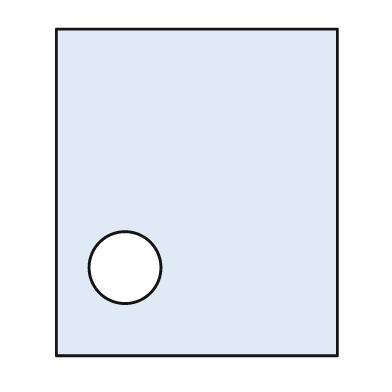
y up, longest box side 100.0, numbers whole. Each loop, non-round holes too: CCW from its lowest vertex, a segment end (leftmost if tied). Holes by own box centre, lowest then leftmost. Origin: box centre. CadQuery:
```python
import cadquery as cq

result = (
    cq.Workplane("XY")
    .moveTo(-43.0, -50.0)
    .lineTo(43.0, -50.0)
    .lineTo(43.0, 50.0)
    .lineTo(-43.0, 50.0)
    .close()
    .moveTo(-22.0, -23.0)
    .circle(11.0)
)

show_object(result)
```